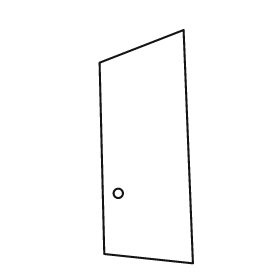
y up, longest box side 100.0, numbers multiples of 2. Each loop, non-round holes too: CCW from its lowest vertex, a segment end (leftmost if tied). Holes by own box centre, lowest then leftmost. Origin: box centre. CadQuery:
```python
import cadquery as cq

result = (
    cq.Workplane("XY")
    .moveTo(20.0, -50.0)
    .lineTo(16.0, 50.0)
    .lineTo(-20.0, 36.0)
    .lineTo(-18.0, -46.0)
    .close()
    .moveTo(-12.0, -20.0)
    .circle(2.0)
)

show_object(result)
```